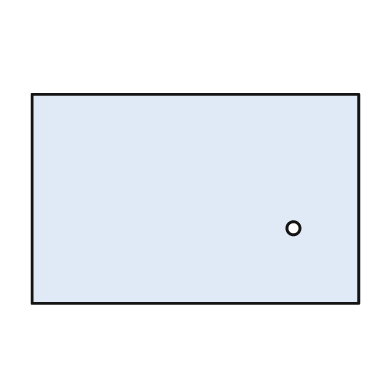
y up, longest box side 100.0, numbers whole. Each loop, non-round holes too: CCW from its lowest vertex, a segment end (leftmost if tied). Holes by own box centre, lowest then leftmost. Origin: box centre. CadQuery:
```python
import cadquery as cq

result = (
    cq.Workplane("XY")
    .moveTo(-50.0, -32.0)
    .lineTo(50.0, -32.0)
    .lineTo(50.0, 32.0)
    .lineTo(-50.0, 32.0)
    .close()
    .moveTo(30.0, -9.0)
    .circle(2.0)
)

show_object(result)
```